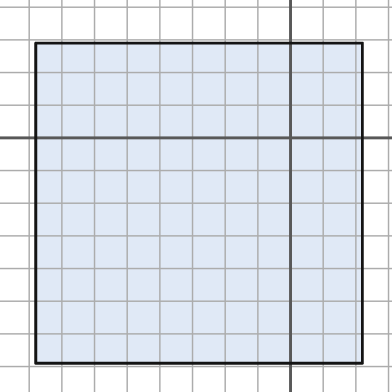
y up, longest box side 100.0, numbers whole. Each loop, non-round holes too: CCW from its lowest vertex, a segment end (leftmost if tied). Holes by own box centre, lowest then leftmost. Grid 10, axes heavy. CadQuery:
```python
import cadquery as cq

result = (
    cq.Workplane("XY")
    .moveTo(-78.0, -69.0)
    .lineTo(22.0, -69.0)
    .lineTo(22.0, 29.0)
    .lineTo(-78.0, 29.0)
    .close()
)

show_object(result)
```